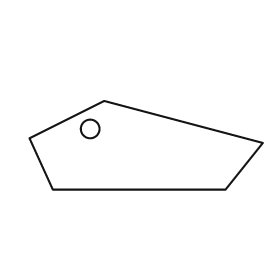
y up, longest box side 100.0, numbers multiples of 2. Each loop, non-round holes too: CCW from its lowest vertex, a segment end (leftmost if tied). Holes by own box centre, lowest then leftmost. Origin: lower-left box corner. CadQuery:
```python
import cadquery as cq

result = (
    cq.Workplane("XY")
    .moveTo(10.0, 0.0)
    .lineTo(84.0, 0.0)
    .lineTo(100.0, 20.0)
    .lineTo(32.0, 38.0)
    .lineTo(0.0, 22.0)
    .close()
    .moveTo(26.0, 26.0)
    .circle(4.0)
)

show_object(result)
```